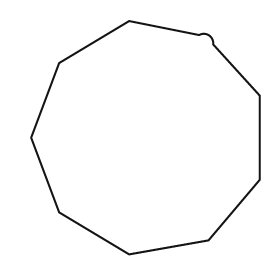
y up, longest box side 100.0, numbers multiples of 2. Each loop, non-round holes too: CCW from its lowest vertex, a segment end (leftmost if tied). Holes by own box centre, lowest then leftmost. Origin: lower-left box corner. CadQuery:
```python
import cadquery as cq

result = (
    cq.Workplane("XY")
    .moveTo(42.0, 0.0)
    .lineTo(76.0, 6.0)
    .lineTo(98.0, 32.0)
    .lineTo(98.0, 68.0)
    .lineTo(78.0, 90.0)
    .threePointArc((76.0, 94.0), (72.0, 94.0))
    .lineTo(42.0, 100.0)
    .lineTo(12.0, 82.0)
    .lineTo(0.0, 50.0)
    .lineTo(12.0, 18.0)
    .close()
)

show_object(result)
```